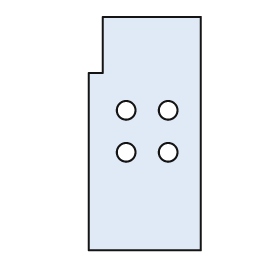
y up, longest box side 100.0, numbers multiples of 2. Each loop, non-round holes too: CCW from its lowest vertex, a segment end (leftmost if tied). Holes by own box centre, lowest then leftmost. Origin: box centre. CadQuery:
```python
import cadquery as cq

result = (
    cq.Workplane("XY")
    .moveTo(-24.0, -50.0)
    .lineTo(24.0, -50.0)
    .lineTo(24.0, 50.0)
    .lineTo(-18.0, 50.0)
    .lineTo(-18.0, 26.0)
    .lineTo(-24.0, 26.0)
    .close()
    .moveTo(-8.0, -8.0)
    .circle(4.0)
    .moveTo(10.0, -8.0)
    .circle(4.0)
    .moveTo(-8.0, 10.0)
    .circle(4.0)
    .moveTo(10.0, 10.0)
    .circle(4.0)
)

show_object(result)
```